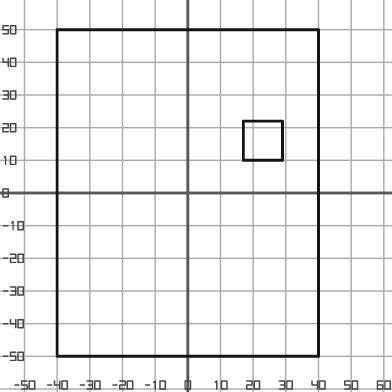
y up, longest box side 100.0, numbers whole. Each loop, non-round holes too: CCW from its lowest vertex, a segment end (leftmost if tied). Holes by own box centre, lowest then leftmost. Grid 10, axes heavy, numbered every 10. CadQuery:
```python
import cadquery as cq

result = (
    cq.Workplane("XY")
    .moveTo(-40.0, -50.0)
    .lineTo(40.0, -50.0)
    .lineTo(40.0, 50.0)
    .lineTo(-40.0, 50.0)
    .close()
    .moveTo(17.0, 10.0)
    .lineTo(29.0, 10.0)
    .lineTo(29.0, 22.0)
    .lineTo(17.0, 22.0)
    .close()
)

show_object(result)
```